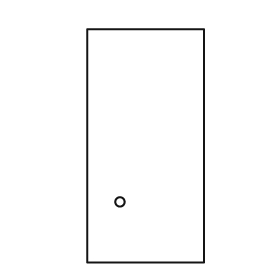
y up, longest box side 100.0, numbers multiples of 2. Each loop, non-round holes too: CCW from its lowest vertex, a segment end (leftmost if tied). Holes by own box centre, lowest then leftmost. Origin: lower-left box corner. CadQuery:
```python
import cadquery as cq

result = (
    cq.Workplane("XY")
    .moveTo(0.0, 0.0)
    .lineTo(50.0, 0.0)
    .lineTo(50.0, 100.0)
    .lineTo(0.0, 100.0)
    .close()
    .moveTo(14.0, 26.0)
    .circle(2.0)
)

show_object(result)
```